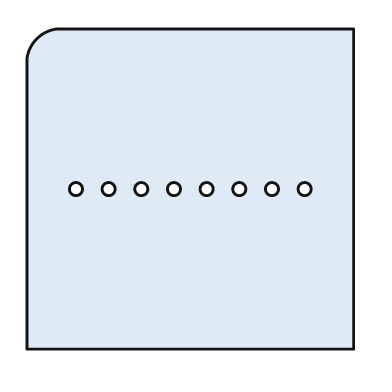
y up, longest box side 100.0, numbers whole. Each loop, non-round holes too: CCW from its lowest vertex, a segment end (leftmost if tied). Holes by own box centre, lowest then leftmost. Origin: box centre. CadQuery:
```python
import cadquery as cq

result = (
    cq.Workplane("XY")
    .moveTo(-50.0, -49.0)
    .lineTo(50.0, -49.0)
    .lineTo(50.0, 49.0)
    .lineTo(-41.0, 49.0)
    .threePointArc((-47.0, 46.0), (-50.0, 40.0))
    .close()
    .moveTo(-35.0, 0.0)
    .circle(2.0)
    .moveTo(-25.0, 0.0)
    .circle(2.0)
    .moveTo(-15.0, 0.0)
    .circle(2.0)
    .moveTo(-5.0, 0.0)
    .circle(2.0)
    .moveTo(5.0, 0.0)
    .circle(2.0)
    .moveTo(15.0, 0.0)
    .circle(2.0)
    .moveTo(25.0, 0.0)
    .circle(2.0)
    .moveTo(35.0, 0.0)
    .circle(2.0)
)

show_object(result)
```